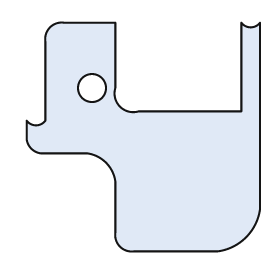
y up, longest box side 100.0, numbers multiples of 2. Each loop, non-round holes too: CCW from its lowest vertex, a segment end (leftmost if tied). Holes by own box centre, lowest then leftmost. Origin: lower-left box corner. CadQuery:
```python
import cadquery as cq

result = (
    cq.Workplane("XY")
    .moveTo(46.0, 0.0)
    .lineTo(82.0, 0.0)
    .threePointArc((94.0, 6.0), (100.0, 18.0))
    .lineTo(100.0, 98.0)
    .threePointArc((96.0, 96.0), (92.0, 98.0))
    .lineTo(92.0, 60.0)
    .lineTo(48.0, 60.0)
    .threePointArc((40.0, 62.0), (38.0, 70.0))
    .lineTo(38.0, 98.0)
    .lineTo(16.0, 98.0)
    .threePointArc((10.0, 96.0), (8.0, 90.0))
    .lineTo(8.0, 56.0)
    .threePointArc((4.0, 54.0), (0.0, 56.0))
    .lineTo(0.0, 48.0)
    .threePointArc((2.0, 44.0), (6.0, 42.0))
    .lineTo(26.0, 42.0)
    .threePointArc((34.0, 38.0), (38.0, 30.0))
    .lineTo(38.0, 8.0)
    .threePointArc((40.0, 2.0), (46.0, 0.0))
    .close()
    .moveTo(28.0, 70.0)
    .circle(6.0)
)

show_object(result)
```